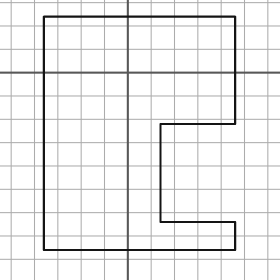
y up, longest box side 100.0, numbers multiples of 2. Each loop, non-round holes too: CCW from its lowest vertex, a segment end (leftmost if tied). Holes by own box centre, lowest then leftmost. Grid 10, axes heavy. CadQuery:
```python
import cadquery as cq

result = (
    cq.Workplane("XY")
    .moveTo(-36.0, -76.0)
    .lineTo(46.0, -76.0)
    .lineTo(46.0, -64.0)
    .lineTo(14.0, -64.0)
    .lineTo(14.0, -22.0)
    .lineTo(46.0, -22.0)
    .lineTo(46.0, 24.0)
    .lineTo(-36.0, 24.0)
    .close()
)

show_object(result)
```